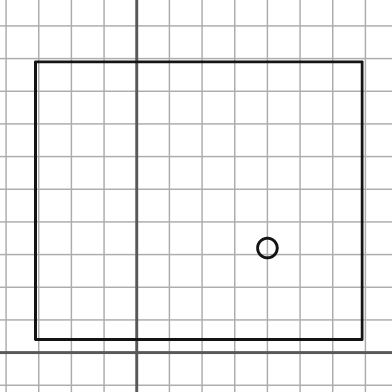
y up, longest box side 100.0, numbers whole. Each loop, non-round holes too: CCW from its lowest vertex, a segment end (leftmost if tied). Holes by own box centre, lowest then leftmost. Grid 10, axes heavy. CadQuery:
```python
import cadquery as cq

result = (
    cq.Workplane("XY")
    .moveTo(-31.0, 4.0)
    .lineTo(69.0, 4.0)
    .lineTo(69.0, 89.0)
    .lineTo(-31.0, 89.0)
    .close()
    .moveTo(40.0, 32.0)
    .circle(3.0)
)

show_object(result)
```